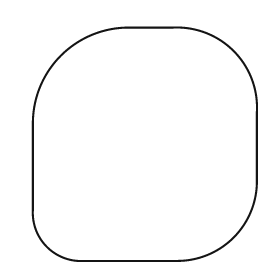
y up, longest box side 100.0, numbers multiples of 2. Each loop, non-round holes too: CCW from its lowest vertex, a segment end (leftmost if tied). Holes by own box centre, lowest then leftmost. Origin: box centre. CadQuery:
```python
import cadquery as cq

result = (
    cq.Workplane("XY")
    .moveTo(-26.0, -50.0)
    .lineTo(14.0, -50.0)
    .threePointArc((38.0, -40.0), (48.0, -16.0))
    .lineTo(48.0, 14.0)
    .threePointArc((38.0, 40.0), (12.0, 50.0))
    .lineTo(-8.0, 50.0)
    .threePointArc((-36.0, 38.0), (-48.0, 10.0))
    .lineTo(-48.0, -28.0)
    .threePointArc((-42.0, -44.0), (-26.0, -50.0))
    .close()
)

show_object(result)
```